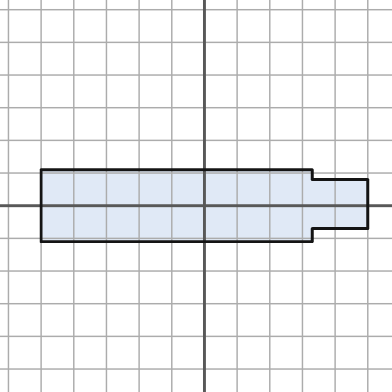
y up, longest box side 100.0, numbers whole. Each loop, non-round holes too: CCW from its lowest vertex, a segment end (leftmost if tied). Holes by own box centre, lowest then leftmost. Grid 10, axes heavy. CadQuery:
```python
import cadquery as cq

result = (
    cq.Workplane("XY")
    .moveTo(-50.0, -11.0)
    .lineTo(33.0, -11.0)
    .lineTo(33.0, -7.0)
    .lineTo(50.0, -7.0)
    .lineTo(50.0, 8.0)
    .lineTo(33.0, 8.0)
    .lineTo(33.0, 11.0)
    .lineTo(-50.0, 11.0)
    .close()
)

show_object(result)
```